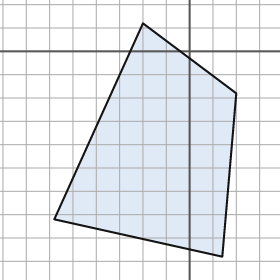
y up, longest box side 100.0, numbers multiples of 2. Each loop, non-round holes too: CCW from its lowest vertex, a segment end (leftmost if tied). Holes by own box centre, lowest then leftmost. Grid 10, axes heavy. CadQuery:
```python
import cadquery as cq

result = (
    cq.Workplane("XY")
    .moveTo(14.0, -88.0)
    .lineTo(20.0, -18.0)
    .lineTo(-20.0, 12.0)
    .lineTo(-58.0, -72.0)
    .close()
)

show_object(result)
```